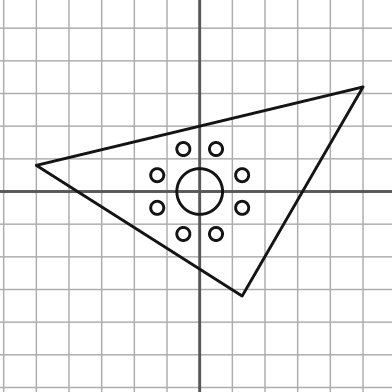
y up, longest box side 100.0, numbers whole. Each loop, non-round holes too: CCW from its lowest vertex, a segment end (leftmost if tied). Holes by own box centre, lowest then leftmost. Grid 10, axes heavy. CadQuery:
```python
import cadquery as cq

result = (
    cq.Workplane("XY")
    .moveTo(13.0, -32.0)
    .lineTo(50.0, 32.0)
    .lineTo(-50.0, 8.0)
    .close()
    .moveTo(-5.0, -13.0)
    .circle(2.0)
    .moveTo(5.0, -13.0)
    .circle(2.0)
    .moveTo(-13.0, -5.0)
    .circle(2.0)
    .moveTo(13.0, -5.0)
    .circle(2.0)
    .moveTo(0.0, 0.0)
    .circle(7.0)
    .moveTo(-13.0, 5.0)
    .circle(2.0)
    .moveTo(13.0, 5.0)
    .circle(2.0)
    .moveTo(-5.0, 13.0)
    .circle(2.0)
    .moveTo(5.0, 13.0)
    .circle(2.0)
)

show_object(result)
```